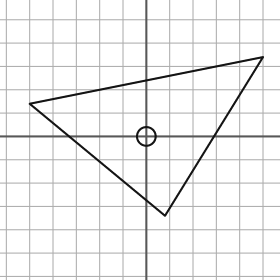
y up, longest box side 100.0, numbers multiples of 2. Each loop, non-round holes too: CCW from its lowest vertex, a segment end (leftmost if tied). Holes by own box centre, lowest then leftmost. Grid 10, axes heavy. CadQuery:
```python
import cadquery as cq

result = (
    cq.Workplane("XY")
    .moveTo(8.0, -34.0)
    .lineTo(50.0, 34.0)
    .lineTo(-50.0, 14.0)
    .close()
    .moveTo(0.0, 0.0)
    .circle(4.0)
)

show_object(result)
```